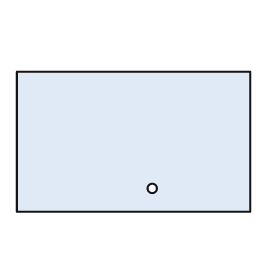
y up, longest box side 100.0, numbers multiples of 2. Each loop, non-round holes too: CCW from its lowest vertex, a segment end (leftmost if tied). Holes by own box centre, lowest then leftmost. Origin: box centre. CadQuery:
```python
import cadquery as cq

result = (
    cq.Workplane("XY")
    .moveTo(-50.0, -30.0)
    .lineTo(50.0, -30.0)
    .lineTo(50.0, 30.0)
    .lineTo(-50.0, 30.0)
    .close()
    .moveTo(8.0, -20.0)
    .circle(2.0)
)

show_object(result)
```